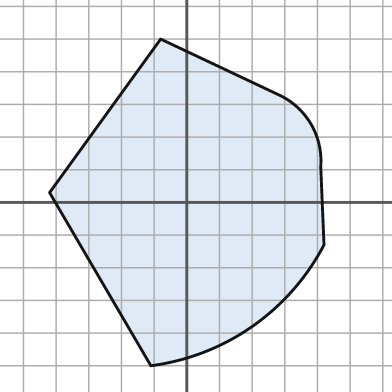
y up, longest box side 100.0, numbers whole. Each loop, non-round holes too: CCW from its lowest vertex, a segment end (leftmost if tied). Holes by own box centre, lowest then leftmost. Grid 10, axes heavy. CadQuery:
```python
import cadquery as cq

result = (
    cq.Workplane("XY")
    .moveTo(-11.0, -50.0)
    .threePointArc((20.0, -38.0), (42.0, -13.0))
    .lineTo(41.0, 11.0)
    .threePointArc((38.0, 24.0), (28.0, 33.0))
    .lineTo(-8.0, 50.0)
    .lineTo(-42.0, 3.0)
    .close()
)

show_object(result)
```